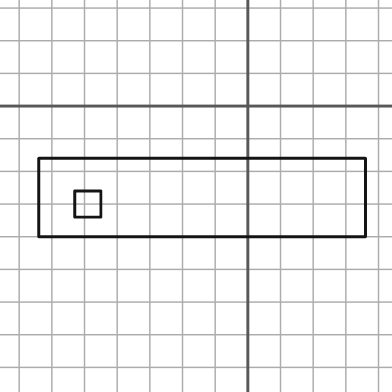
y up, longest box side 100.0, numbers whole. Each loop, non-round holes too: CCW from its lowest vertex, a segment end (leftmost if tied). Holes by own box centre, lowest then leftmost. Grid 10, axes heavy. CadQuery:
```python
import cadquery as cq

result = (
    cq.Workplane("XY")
    .moveTo(-64.0, -40.0)
    .lineTo(36.0, -40.0)
    .lineTo(36.0, -16.0)
    .lineTo(-64.0, -16.0)
    .close()
    .moveTo(-53.0, -34.0)
    .lineTo(-45.0, -34.0)
    .lineTo(-45.0, -26.0)
    .lineTo(-53.0, -26.0)
    .close()
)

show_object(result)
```